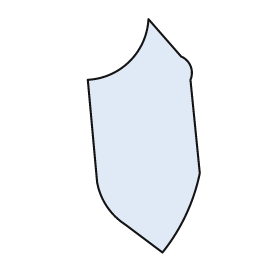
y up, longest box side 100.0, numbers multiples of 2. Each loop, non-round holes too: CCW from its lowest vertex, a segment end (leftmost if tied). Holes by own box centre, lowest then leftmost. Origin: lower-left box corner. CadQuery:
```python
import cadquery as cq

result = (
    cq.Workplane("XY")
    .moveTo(32.0, 0.0)
    .threePointArc((42.0, 16.0), (48.0, 34.0))
    .lineTo(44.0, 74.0)
    .threePointArc((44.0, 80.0), (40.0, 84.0))
    .lineTo(26.0, 100.0)
    .threePointArc((18.0, 82.0), (0.0, 74.0))
    .lineTo(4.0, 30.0)
    .threePointArc((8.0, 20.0), (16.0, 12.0))
    .close()
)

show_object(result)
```